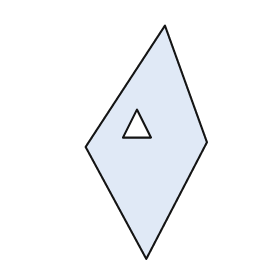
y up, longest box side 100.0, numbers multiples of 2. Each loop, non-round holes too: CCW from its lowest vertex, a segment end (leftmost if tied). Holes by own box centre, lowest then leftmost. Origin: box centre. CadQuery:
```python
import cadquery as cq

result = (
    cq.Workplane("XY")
    .moveTo(0.0, -50.0)
    .lineTo(26.0, 0.0)
    .lineTo(8.0, 50.0)
    .lineTo(-26.0, -2.0)
    .close()
    .moveTo(-10.0, 2.0)
    .lineTo(2.0, 2.0)
    .lineTo(-4.0, 14.0)
    .close()
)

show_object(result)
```